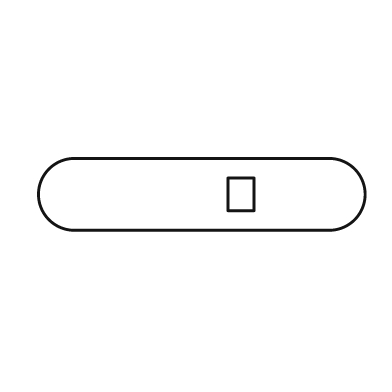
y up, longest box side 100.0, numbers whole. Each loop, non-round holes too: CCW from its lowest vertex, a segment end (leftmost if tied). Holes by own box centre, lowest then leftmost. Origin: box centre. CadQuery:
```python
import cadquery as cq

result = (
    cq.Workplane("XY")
    .moveTo(-39.0, -11.0)
    .lineTo(39.0, -11.0)
    .threePointArc((50.0, 0.0), (39.0, 11.0))
    .lineTo(-39.0, 11.0)
    .threePointArc((-50.0, 0.0), (-39.0, -11.0))
    .close()
    .moveTo(8.0, -5.0)
    .lineTo(16.0, -5.0)
    .lineTo(16.0, 5.0)
    .lineTo(8.0, 5.0)
    .close()
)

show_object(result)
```